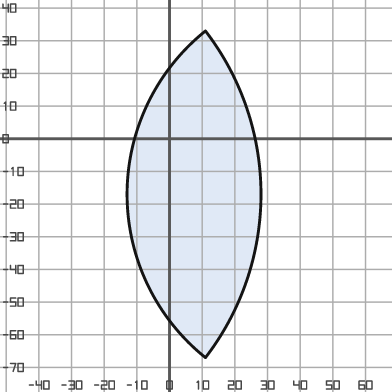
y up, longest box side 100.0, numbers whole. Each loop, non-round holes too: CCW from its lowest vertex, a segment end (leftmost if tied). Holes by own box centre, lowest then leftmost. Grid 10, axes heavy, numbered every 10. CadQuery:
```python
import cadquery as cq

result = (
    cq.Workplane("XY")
    .moveTo(11.0, -67.0)
    .threePointArc((28.0, -17.0), (11.0, 33.0))
    .threePointArc((-13.0, -17.0), (11.0, -67.0))
    .close()
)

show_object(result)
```